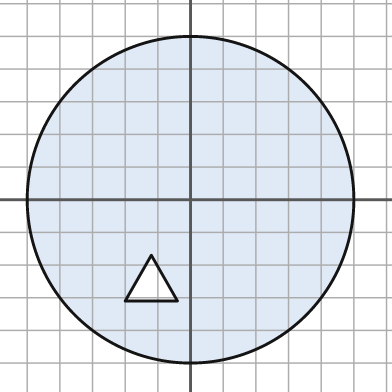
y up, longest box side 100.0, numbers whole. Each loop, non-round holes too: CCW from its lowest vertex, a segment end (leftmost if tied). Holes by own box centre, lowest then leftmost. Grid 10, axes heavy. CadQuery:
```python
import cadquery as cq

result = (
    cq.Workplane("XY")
    .moveTo(0.0, 0.0)
    .circle(50.0)
    .moveTo(-20.0, -31.0)
    .lineTo(-4.0, -31.0)
    .lineTo(-12.0, -17.0)
    .close()
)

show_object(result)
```